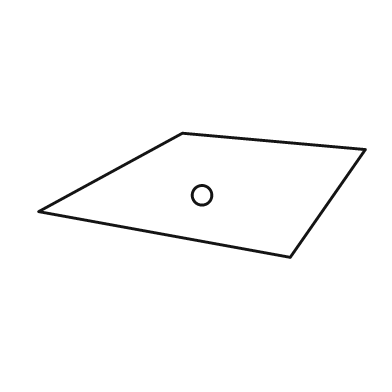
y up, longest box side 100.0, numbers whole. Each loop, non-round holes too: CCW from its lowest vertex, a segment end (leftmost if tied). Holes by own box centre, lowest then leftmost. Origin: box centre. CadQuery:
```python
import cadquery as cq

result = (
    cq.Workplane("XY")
    .moveTo(27.0, -19.0)
    .lineTo(50.0, 14.0)
    .lineTo(-6.0, 19.0)
    .lineTo(-50.0, -5.0)
    .close()
    .moveTo(0.0, 0.0)
    .circle(3.0)
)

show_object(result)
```